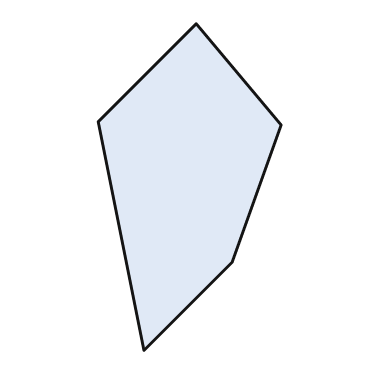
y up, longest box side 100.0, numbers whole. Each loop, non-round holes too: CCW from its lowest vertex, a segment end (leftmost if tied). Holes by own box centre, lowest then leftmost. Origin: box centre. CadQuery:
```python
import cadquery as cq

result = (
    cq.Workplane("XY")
    .moveTo(-14.0, -50.0)
    .lineTo(13.0, -23.0)
    .lineTo(28.0, 19.0)
    .lineTo(2.0, 50.0)
    .lineTo(-28.0, 20.0)
    .close()
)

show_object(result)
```